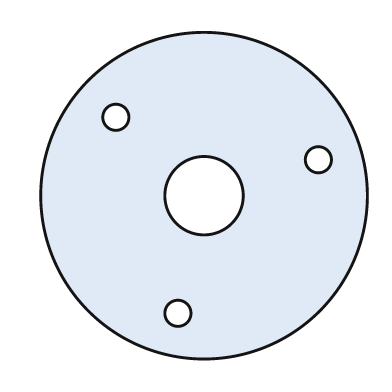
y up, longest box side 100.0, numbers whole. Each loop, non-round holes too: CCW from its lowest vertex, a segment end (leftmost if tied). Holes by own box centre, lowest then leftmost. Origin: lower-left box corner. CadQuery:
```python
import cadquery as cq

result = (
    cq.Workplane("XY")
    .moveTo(50.0, 50.0)
    .circle(50.0)
    .moveTo(42.0, 14.0)
    .circle(4.0)
    .moveTo(50.0, 50.0)
    .circle(12.0)
    .moveTo(85.0, 61.0)
    .circle(4.0)
    .moveTo(23.0, 74.0)
    .circle(4.0)
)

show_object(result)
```